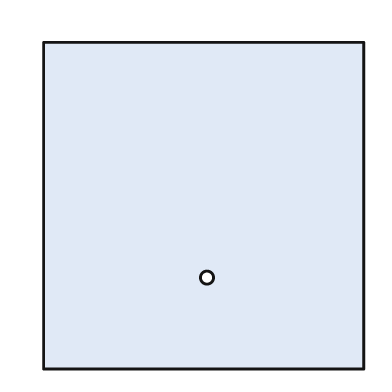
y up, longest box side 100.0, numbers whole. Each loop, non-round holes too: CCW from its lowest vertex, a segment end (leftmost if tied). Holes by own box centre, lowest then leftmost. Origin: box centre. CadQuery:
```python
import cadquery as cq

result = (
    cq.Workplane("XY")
    .moveTo(-49.0, -50.0)
    .lineTo(49.0, -50.0)
    .lineTo(49.0, 50.0)
    .lineTo(-49.0, 50.0)
    .close()
    .moveTo(1.0, -22.0)
    .circle(2.0)
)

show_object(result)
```